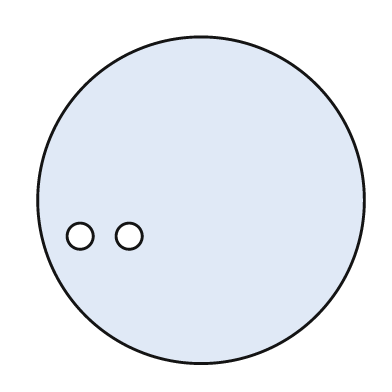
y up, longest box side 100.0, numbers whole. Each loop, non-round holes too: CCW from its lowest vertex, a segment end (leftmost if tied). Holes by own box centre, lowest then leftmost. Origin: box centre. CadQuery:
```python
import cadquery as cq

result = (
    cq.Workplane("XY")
    .moveTo(0.0, 0.0)
    .circle(50.0)
    .moveTo(-37.0, -11.0)
    .circle(4.0)
    .moveTo(-22.0, -11.0)
    .circle(4.0)
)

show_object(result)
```